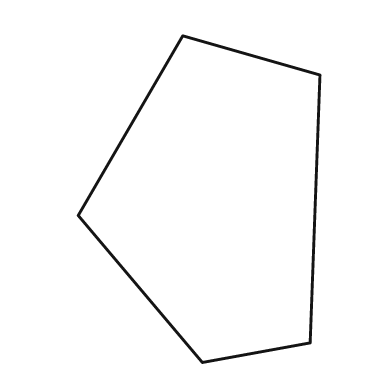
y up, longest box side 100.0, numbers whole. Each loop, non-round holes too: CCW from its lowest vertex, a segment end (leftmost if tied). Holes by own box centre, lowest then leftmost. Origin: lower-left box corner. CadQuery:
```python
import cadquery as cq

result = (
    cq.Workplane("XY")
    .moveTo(38.0, 0.0)
    .lineTo(71.0, 6.0)
    .lineTo(74.0, 88.0)
    .lineTo(32.0, 100.0)
    .lineTo(0.0, 45.0)
    .close()
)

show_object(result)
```